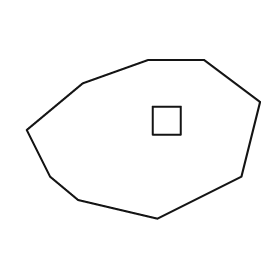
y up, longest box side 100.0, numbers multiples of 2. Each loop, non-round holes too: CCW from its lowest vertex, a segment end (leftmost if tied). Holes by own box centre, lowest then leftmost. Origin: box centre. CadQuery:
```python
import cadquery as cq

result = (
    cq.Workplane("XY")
    .moveTo(6.0, -34.0)
    .lineTo(42.0, -16.0)
    .lineTo(50.0, 16.0)
    .lineTo(26.0, 34.0)
    .lineTo(2.0, 34.0)
    .lineTo(-26.0, 24.0)
    .lineTo(-50.0, 4.0)
    .lineTo(-40.0, -16.0)
    .lineTo(-28.0, -26.0)
    .close()
    .moveTo(4.0, 2.0)
    .lineTo(16.0, 2.0)
    .lineTo(16.0, 14.0)
    .lineTo(4.0, 14.0)
    .close()
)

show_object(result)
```